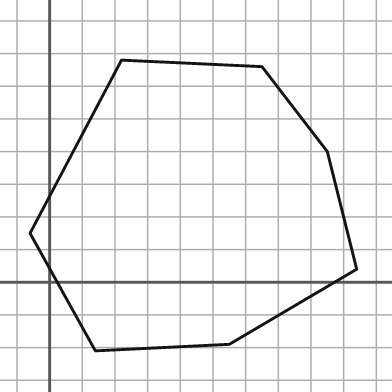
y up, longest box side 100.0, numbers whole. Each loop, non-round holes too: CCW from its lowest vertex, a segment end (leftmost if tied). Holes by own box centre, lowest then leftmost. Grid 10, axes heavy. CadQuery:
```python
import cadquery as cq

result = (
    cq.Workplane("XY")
    .moveTo(14.0, -21.0)
    .lineTo(55.0, -19.0)
    .lineTo(94.0, 4.0)
    .lineTo(85.0, 40.0)
    .lineTo(65.0, 66.0)
    .lineTo(22.0, 68.0)
    .lineTo(-6.0, 15.0)
    .close()
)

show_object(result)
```